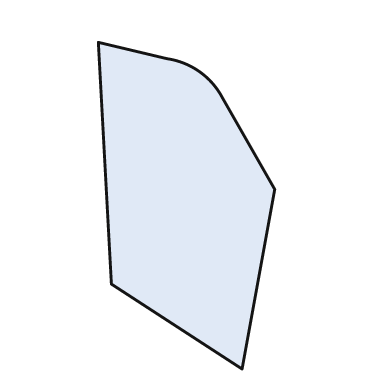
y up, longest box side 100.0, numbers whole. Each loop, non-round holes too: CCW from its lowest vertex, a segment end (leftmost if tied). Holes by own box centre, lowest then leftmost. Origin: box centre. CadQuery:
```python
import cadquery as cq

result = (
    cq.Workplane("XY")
    .moveTo(17.0, -50.0)
    .lineTo(27.0, 5.0)
    .lineTo(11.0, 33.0)
    .threePointArc((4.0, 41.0), (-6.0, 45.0))
    .lineTo(-27.0, 50.0)
    .lineTo(-23.0, -24.0)
    .close()
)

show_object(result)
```